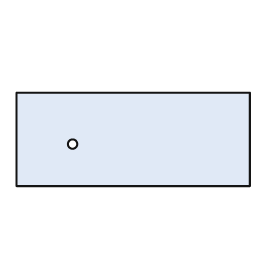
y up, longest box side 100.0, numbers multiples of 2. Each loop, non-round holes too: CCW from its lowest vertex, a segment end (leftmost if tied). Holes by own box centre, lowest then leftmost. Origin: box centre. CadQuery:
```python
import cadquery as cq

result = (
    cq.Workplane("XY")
    .moveTo(-50.0, -20.0)
    .lineTo(50.0, -20.0)
    .lineTo(50.0, 20.0)
    .lineTo(-50.0, 20.0)
    .close()
    .moveTo(-26.0, -2.0)
    .circle(2.0)
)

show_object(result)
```